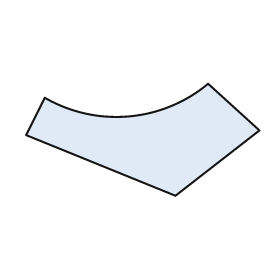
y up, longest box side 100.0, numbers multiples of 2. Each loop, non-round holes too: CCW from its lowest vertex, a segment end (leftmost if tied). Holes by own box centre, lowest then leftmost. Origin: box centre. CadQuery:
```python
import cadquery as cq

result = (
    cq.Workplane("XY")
    .moveTo(14.0, -24.0)
    .lineTo(50.0, 4.0)
    .lineTo(28.0, 24.0)
    .threePointArc((-6.0, 10.0), (-42.0, 18.0))
    .lineTo(-50.0, 2.0)
    .close()
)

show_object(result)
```